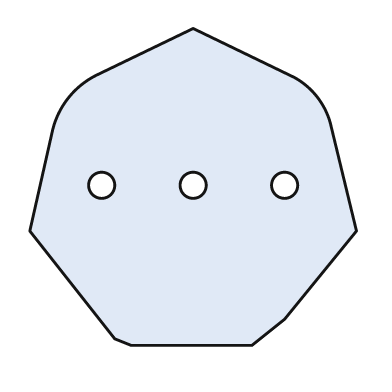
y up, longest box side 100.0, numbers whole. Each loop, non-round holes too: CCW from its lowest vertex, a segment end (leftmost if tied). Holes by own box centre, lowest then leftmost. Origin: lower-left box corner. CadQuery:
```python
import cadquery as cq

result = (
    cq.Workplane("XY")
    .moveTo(31.0, 0.0)
    .lineTo(68.0, 0.0)
    .lineTo(78.0, 8.0)
    .lineTo(100.0, 35.0)
    .lineTo(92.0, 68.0)
    .threePointArc((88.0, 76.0), (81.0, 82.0))
    .lineTo(50.0, 97.0)
    .lineTo(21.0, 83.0)
    .threePointArc((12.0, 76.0), (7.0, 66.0))
    .lineTo(0.0, 35.0)
    .lineTo(26.0, 2.0)
    .close()
    .moveTo(22.0, 49.0)
    .circle(4.0)
    .moveTo(50.0, 49.0)
    .circle(4.0)
    .moveTo(78.0, 49.0)
    .circle(4.0)
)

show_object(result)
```